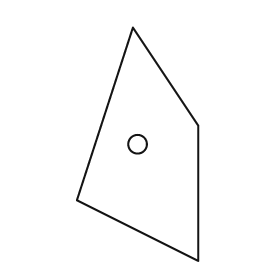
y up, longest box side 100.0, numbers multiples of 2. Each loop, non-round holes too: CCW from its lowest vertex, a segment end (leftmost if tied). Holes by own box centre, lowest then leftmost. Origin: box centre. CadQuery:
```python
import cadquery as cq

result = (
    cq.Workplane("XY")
    .moveTo(26.0, -50.0)
    .lineTo(26.0, 8.0)
    .lineTo(-2.0, 50.0)
    .lineTo(-26.0, -24.0)
    .close()
    .moveTo(0.0, 0.0)
    .circle(4.0)
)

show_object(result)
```